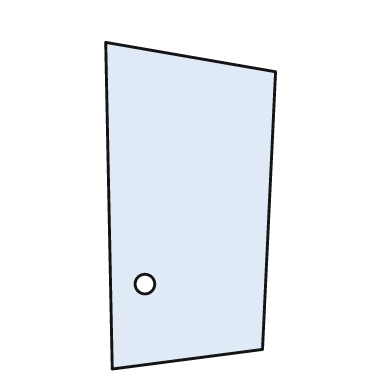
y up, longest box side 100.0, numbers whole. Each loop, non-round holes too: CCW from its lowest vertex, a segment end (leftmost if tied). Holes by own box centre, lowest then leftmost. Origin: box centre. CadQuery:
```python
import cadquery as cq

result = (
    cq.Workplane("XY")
    .moveTo(-24.0, -50.0)
    .lineTo(22.0, -44.0)
    .lineTo(26.0, 41.0)
    .lineTo(-26.0, 50.0)
    .close()
    .moveTo(-14.0, -24.0)
    .circle(3.0)
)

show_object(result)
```